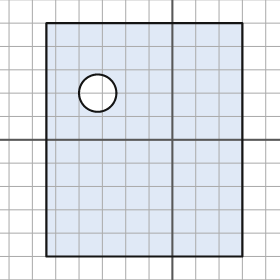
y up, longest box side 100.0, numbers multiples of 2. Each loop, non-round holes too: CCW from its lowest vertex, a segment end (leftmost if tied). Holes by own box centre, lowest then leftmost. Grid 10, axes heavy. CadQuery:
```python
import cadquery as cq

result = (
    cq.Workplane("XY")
    .moveTo(-54.0, -50.0)
    .lineTo(30.0, -50.0)
    .lineTo(30.0, 50.0)
    .lineTo(-54.0, 50.0)
    .close()
    .moveTo(-32.0, 20.0)
    .circle(8.0)
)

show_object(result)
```